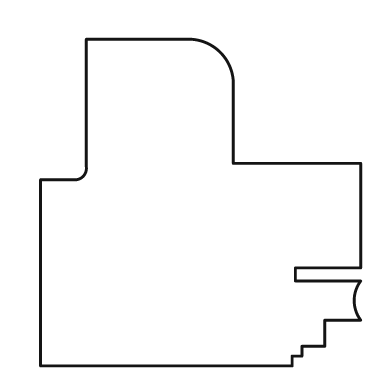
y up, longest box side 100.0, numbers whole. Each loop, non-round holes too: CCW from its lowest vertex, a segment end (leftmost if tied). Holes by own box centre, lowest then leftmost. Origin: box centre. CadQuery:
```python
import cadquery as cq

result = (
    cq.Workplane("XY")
    .moveTo(-49.0, -50.0)
    .lineTo(28.0, -50.0)
    .lineTo(28.0, -47.0)
    .lineTo(31.0, -47.0)
    .lineTo(31.0, -44.0)
    .lineTo(38.0, -44.0)
    .lineTo(38.0, -36.0)
    .lineTo(49.0, -36.0)
    .threePointArc((47.0, -30.0), (49.0, -24.0))
    .lineTo(29.0, -24.0)
    .lineTo(29.0, -20.0)
    .lineTo(49.0, -20.0)
    .lineTo(49.0, 12.0)
    .lineTo(10.0, 12.0)
    .lineTo(10.0, 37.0)
    .threePointArc((6.0, 46.0), (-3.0, 50.0))
    .lineTo(-35.0, 50.0)
    .lineTo(-35.0, 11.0)
    .threePointArc((-36.0, 8.0), (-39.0, 7.0))
    .lineTo(-49.0, 7.0)
    .close()
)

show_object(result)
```